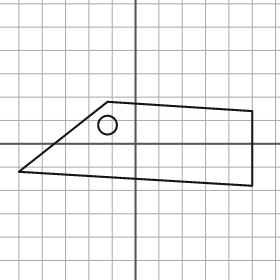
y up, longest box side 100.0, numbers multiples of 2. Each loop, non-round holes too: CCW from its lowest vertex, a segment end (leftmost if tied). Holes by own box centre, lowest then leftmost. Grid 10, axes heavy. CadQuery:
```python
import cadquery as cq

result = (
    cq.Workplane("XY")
    .moveTo(50.0, -18.0)
    .lineTo(50.0, 14.0)
    .lineTo(-12.0, 18.0)
    .lineTo(-50.0, -12.0)
    .close()
    .moveTo(-12.0, 8.0)
    .circle(4.0)
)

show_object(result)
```